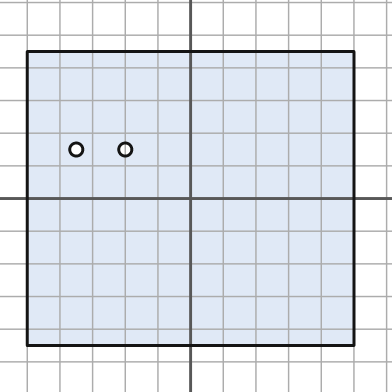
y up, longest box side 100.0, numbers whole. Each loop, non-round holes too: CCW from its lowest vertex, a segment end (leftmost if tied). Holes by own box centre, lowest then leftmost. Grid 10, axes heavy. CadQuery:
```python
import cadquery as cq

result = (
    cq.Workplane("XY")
    .moveTo(-50.0, -45.0)
    .lineTo(50.0, -45.0)
    .lineTo(50.0, 45.0)
    .lineTo(-50.0, 45.0)
    .close()
    .moveTo(-35.0, 15.0)
    .circle(2.0)
    .moveTo(-20.0, 15.0)
    .circle(2.0)
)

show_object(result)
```